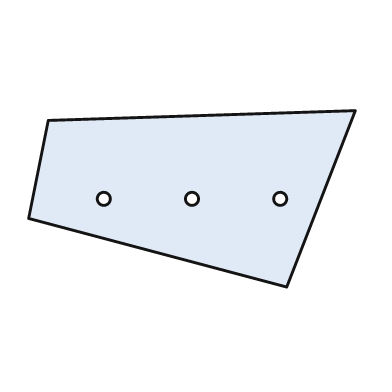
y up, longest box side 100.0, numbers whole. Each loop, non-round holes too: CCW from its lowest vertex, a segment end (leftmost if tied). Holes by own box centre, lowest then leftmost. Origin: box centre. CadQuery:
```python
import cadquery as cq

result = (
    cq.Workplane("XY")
    .moveTo(29.0, -27.0)
    .lineTo(50.0, 27.0)
    .lineTo(-44.0, 24.0)
    .lineTo(-50.0, -6.0)
    .close()
    .moveTo(-27.0, 0.0)
    .circle(2.0)
    .moveTo(0.0, 0.0)
    .circle(2.0)
    .moveTo(27.0, 0.0)
    .circle(2.0)
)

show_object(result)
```